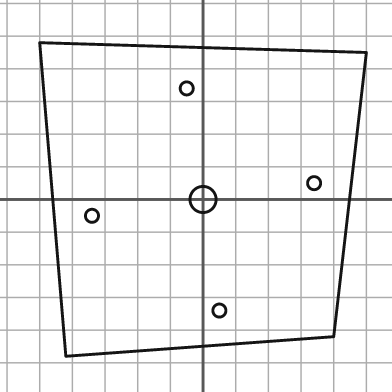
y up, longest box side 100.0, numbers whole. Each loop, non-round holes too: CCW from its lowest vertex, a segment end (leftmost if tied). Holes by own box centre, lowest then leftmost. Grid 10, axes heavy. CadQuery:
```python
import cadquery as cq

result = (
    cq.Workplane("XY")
    .moveTo(-42.0, -48.0)
    .lineTo(40.0, -42.0)
    .lineTo(50.0, 45.0)
    .lineTo(-50.0, 48.0)
    .close()
    .moveTo(5.0, -34.0)
    .circle(2.0)
    .moveTo(-34.0, -5.0)
    .circle(2.0)
    .moveTo(0.0, 0.0)
    .circle(4.0)
    .moveTo(34.0, 5.0)
    .circle(2.0)
    .moveTo(-5.0, 34.0)
    .circle(2.0)
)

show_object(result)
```